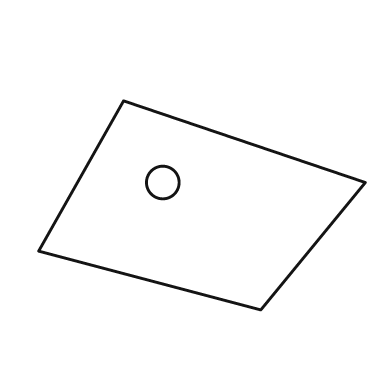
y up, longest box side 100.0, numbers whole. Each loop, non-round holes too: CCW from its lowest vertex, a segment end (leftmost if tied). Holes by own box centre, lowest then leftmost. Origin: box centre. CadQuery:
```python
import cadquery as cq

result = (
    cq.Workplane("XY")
    .moveTo(18.0, -32.0)
    .lineTo(50.0, 7.0)
    .lineTo(-24.0, 32.0)
    .lineTo(-50.0, -14.0)
    .close()
    .moveTo(-12.0, 7.0)
    .circle(5.0)
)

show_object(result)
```